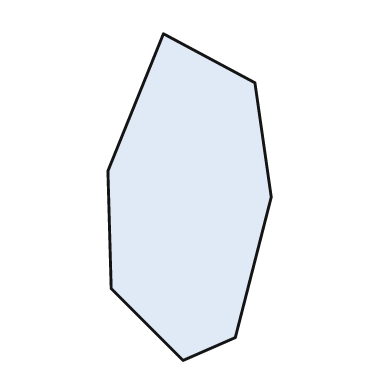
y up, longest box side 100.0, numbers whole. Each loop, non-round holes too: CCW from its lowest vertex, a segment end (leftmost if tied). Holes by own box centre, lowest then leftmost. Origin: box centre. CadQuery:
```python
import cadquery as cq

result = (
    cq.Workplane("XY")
    .moveTo(-2.0, -50.0)
    .lineTo(14.0, -43.0)
    .lineTo(25.0, 0.0)
    .lineTo(20.0, 35.0)
    .lineTo(-8.0, 50.0)
    .lineTo(-25.0, 8.0)
    .lineTo(-24.0, -28.0)
    .close()
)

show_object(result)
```